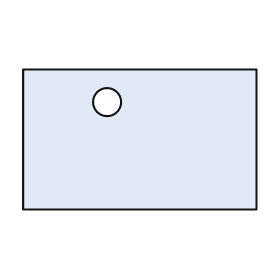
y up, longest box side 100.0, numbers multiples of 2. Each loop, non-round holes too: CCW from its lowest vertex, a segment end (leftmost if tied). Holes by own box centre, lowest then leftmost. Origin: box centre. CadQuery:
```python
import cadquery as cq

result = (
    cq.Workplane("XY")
    .moveTo(-50.0, -30.0)
    .lineTo(50.0, -30.0)
    .lineTo(50.0, 30.0)
    .lineTo(-50.0, 30.0)
    .close()
    .moveTo(-14.0, 16.0)
    .circle(6.0)
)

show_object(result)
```